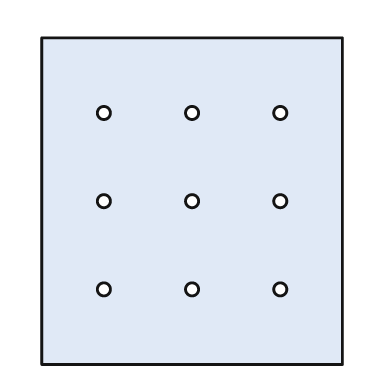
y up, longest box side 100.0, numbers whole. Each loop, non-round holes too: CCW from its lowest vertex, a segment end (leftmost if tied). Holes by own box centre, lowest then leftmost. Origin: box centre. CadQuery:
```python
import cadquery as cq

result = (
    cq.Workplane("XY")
    .moveTo(-46.0, -50.0)
    .lineTo(46.0, -50.0)
    .lineTo(46.0, 50.0)
    .lineTo(-46.0, 50.0)
    .close()
    .moveTo(-27.0, -27.0)
    .circle(2.0)
    .moveTo(0.0, -27.0)
    .circle(2.0)
    .moveTo(27.0, -27.0)
    .circle(2.0)
    .moveTo(-27.0, 0.0)
    .circle(2.0)
    .moveTo(0.0, 0.0)
    .circle(2.0)
    .moveTo(27.0, 0.0)
    .circle(2.0)
    .moveTo(-27.0, 27.0)
    .circle(2.0)
    .moveTo(0.0, 27.0)
    .circle(2.0)
    .moveTo(27.0, 27.0)
    .circle(2.0)
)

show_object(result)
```